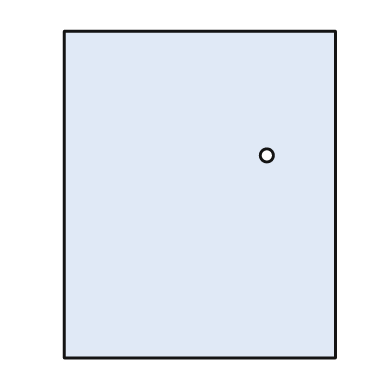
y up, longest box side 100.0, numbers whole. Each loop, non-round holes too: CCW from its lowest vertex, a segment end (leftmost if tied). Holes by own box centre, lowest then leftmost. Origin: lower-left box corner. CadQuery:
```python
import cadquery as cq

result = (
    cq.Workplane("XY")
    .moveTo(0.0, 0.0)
    .lineTo(83.0, 0.0)
    .lineTo(83.0, 100.0)
    .lineTo(0.0, 100.0)
    .close()
    .moveTo(62.0, 62.0)
    .circle(2.0)
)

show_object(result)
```